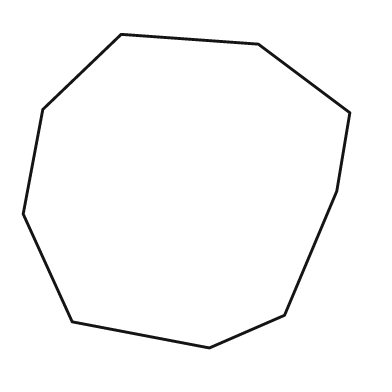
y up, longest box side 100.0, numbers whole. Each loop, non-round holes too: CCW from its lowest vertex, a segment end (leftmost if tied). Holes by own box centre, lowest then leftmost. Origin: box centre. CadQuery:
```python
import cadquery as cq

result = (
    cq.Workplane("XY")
    .moveTo(7.0, -48.0)
    .lineTo(30.0, -38.0)
    .lineTo(46.0, 0.0)
    .lineTo(50.0, 24.0)
    .lineTo(22.0, 45.0)
    .lineTo(-20.0, 48.0)
    .lineTo(-44.0, 25.0)
    .lineTo(-50.0, -7.0)
    .lineTo(-35.0, -40.0)
    .close()
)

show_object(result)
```